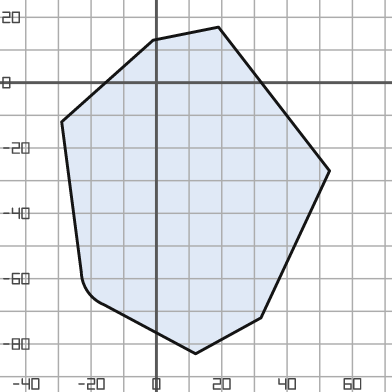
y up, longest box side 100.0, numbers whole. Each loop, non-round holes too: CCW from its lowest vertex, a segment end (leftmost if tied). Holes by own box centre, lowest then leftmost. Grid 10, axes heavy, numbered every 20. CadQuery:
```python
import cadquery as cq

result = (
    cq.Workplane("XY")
    .moveTo(12.0, -83.0)
    .lineTo(32.0, -72.0)
    .lineTo(53.0, -27.0)
    .lineTo(19.0, 17.0)
    .lineTo(-1.0, 13.0)
    .lineTo(-29.0, -12.0)
    .lineTo(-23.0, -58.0)
    .threePointArc((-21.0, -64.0), (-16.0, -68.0))
    .close()
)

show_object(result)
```